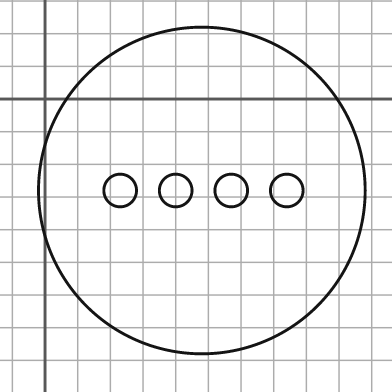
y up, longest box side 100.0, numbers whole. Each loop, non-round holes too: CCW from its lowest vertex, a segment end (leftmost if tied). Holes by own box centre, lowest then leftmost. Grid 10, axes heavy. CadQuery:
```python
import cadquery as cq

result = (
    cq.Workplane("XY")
    .moveTo(48.0, -28.0)
    .circle(50.0)
    .moveTo(23.0, -28.0)
    .circle(5.0)
    .moveTo(40.0, -28.0)
    .circle(5.0)
    .moveTo(57.0, -28.0)
    .circle(5.0)
    .moveTo(74.0, -28.0)
    .circle(5.0)
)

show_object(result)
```